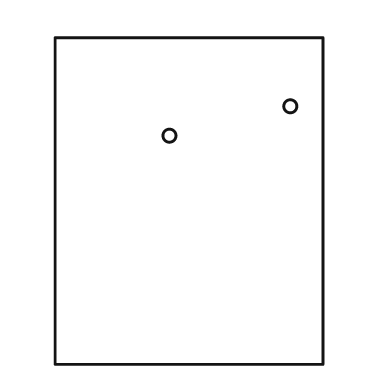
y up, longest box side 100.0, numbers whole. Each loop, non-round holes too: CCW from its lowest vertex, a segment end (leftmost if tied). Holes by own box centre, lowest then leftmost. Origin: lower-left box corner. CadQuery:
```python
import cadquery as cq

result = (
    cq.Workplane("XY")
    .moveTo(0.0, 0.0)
    .lineTo(82.0, 0.0)
    .lineTo(82.0, 100.0)
    .lineTo(0.0, 100.0)
    .close()
    .moveTo(35.0, 70.0)
    .circle(2.0)
    .moveTo(72.0, 79.0)
    .circle(2.0)
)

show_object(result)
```